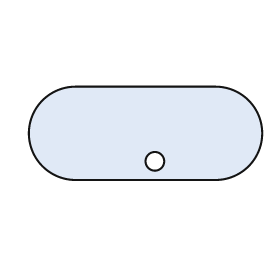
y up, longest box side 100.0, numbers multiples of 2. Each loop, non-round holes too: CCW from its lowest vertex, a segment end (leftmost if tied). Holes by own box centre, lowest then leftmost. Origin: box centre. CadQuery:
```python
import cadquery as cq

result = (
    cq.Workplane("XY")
    .moveTo(-30.0, -20.0)
    .lineTo(30.0, -20.0)
    .threePointArc((50.0, 0.0), (30.0, 20.0))
    .lineTo(-30.0, 20.0)
    .threePointArc((-50.0, 0.0), (-30.0, -20.0))
    .close()
    .moveTo(4.0, -12.0)
    .circle(4.0)
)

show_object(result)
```